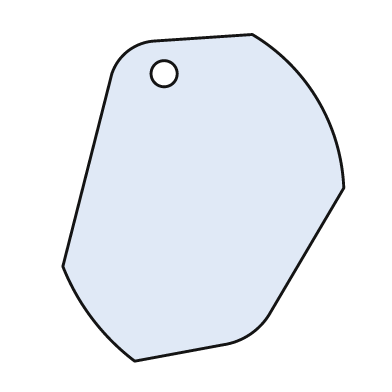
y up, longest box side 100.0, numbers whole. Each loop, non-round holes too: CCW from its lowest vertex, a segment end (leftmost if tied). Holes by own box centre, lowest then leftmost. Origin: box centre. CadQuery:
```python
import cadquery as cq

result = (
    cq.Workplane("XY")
    .moveTo(-21.0, -50.0)
    .lineTo(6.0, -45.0)
    .threePointArc((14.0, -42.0), (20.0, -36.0))
    .lineTo(43.0, 3.0)
    .threePointArc((35.0, 30.0), (15.0, 50.0))
    .lineTo(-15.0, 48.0)
    .threePointArc((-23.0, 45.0), (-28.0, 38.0))
    .lineTo(-43.0, -21.0)
    .threePointArc((-34.0, -37.0), (-21.0, -50.0))
    .close()
    .moveTo(-12.0, 38.0)
    .circle(4.0)
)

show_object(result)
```